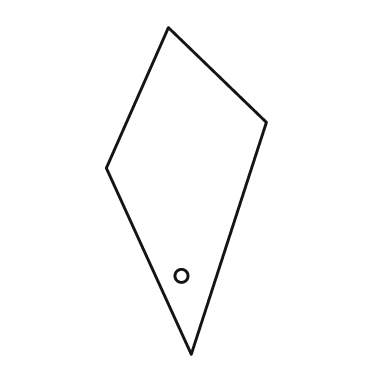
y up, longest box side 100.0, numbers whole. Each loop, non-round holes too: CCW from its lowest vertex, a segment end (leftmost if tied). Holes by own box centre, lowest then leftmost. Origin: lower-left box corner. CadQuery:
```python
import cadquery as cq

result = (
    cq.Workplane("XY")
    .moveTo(26.0, 0.0)
    .lineTo(49.0, 71.0)
    .lineTo(19.0, 100.0)
    .lineTo(0.0, 57.0)
    .close()
    .moveTo(23.0, 24.0)
    .circle(2.0)
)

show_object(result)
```